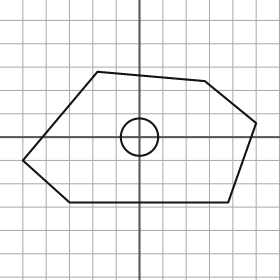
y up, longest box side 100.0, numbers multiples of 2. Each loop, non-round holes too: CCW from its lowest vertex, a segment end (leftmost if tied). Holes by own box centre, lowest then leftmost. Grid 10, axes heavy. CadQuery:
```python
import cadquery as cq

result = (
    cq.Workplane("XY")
    .moveTo(-30.0, -28.0)
    .lineTo(38.0, -28.0)
    .lineTo(50.0, 6.0)
    .lineTo(28.0, 24.0)
    .lineTo(-18.0, 28.0)
    .lineTo(-50.0, -10.0)
    .close()
    .moveTo(0.0, 0.0)
    .circle(8.0)
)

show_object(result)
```